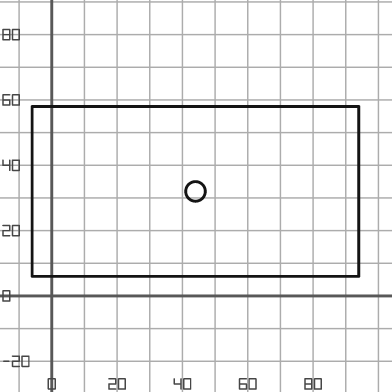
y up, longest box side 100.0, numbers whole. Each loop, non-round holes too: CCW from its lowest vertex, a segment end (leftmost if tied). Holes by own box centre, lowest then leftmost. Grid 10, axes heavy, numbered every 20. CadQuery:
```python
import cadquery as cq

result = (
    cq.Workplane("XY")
    .moveTo(-6.0, 6.0)
    .lineTo(94.0, 6.0)
    .lineTo(94.0, 58.0)
    .lineTo(-6.0, 58.0)
    .close()
    .moveTo(44.0, 32.0)
    .circle(3.0)
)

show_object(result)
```